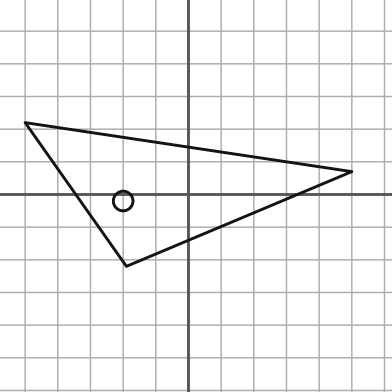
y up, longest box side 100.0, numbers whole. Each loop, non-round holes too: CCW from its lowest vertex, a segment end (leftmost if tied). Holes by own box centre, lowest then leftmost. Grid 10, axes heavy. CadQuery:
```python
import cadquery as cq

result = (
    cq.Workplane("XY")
    .moveTo(-19.0, -22.0)
    .lineTo(50.0, 7.0)
    .lineTo(-50.0, 22.0)
    .close()
    .moveTo(-20.0, -2.0)
    .circle(3.0)
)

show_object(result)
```